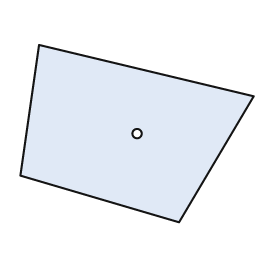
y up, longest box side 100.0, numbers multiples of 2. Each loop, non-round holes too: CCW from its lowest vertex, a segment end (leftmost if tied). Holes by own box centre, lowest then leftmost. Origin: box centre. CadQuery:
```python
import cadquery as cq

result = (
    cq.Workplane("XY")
    .moveTo(18.0, -38.0)
    .lineTo(50.0, 16.0)
    .lineTo(-42.0, 38.0)
    .lineTo(-50.0, -18.0)
    .close()
    .moveTo(0.0, 0.0)
    .circle(2.0)
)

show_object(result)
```